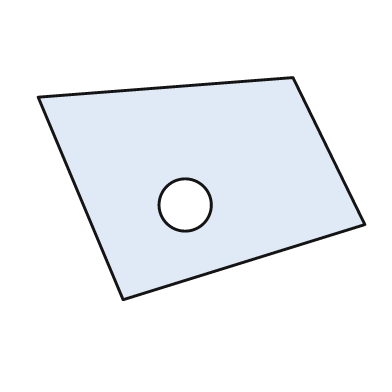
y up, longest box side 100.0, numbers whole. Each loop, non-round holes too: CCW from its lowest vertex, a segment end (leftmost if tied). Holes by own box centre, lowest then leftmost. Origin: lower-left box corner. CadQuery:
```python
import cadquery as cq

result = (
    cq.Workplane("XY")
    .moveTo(26.0, 0.0)
    .lineTo(100.0, 23.0)
    .lineTo(78.0, 68.0)
    .lineTo(0.0, 62.0)
    .close()
    .moveTo(45.0, 29.0)
    .circle(8.0)
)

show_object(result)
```